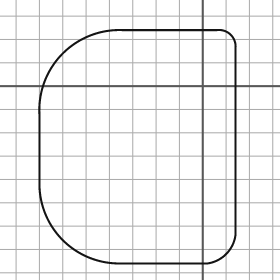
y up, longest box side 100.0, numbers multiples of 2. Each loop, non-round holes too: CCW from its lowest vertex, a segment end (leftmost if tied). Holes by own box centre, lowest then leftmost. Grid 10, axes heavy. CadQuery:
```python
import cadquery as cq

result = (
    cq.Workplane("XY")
    .moveTo(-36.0, -76.0)
    .lineTo(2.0, -76.0)
    .threePointArc((10.0, -72.0), (14.0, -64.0))
    .lineTo(14.0, 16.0)
    .threePointArc((12.0, 22.0), (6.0, 24.0))
    .lineTo(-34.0, 24.0)
    .threePointArc((-60.0, 14.0), (-70.0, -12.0))
    .lineTo(-70.0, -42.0)
    .threePointArc((-60.0, -66.0), (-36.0, -76.0))
    .close()
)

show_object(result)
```